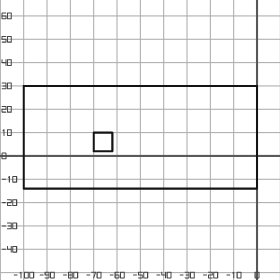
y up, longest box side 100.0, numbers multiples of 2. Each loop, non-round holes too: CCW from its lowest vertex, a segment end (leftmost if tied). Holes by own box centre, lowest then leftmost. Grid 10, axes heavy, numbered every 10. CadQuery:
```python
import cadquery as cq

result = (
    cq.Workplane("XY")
    .moveTo(-100.0, -14.0)
    .lineTo(0.0, -14.0)
    .lineTo(0.0, 30.0)
    .lineTo(-100.0, 30.0)
    .close()
    .moveTo(-70.0, 2.0)
    .lineTo(-62.0, 2.0)
    .lineTo(-62.0, 10.0)
    .lineTo(-70.0, 10.0)
    .close()
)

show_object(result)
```